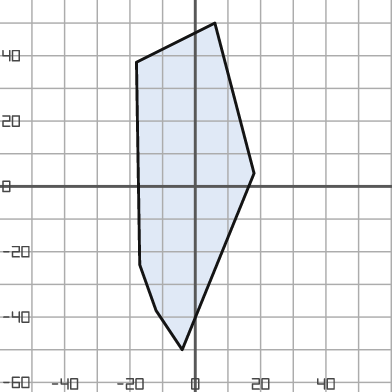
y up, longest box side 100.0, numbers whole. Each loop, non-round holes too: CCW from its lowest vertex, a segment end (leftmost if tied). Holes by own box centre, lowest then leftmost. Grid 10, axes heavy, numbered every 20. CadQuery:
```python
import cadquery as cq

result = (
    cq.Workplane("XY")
    .moveTo(-4.0, -50.0)
    .lineTo(18.0, 4.0)
    .lineTo(6.0, 50.0)
    .lineTo(-18.0, 38.0)
    .lineTo(-17.0, -24.0)
    .lineTo(-12.0, -38.0)
    .close()
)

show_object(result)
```